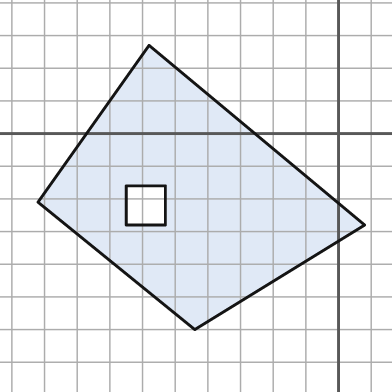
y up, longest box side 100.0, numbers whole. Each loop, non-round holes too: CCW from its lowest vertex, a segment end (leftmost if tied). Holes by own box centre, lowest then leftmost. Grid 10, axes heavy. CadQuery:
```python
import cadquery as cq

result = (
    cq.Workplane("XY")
    .moveTo(-44.0, -60.0)
    .lineTo(8.0, -28.0)
    .lineTo(-58.0, 27.0)
    .lineTo(-92.0, -21.0)
    .close()
    .moveTo(-65.0, -28.0)
    .lineTo(-53.0, -28.0)
    .lineTo(-53.0, -16.0)
    .lineTo(-65.0, -16.0)
    .close()
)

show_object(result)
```